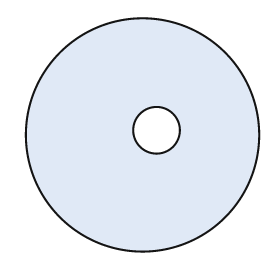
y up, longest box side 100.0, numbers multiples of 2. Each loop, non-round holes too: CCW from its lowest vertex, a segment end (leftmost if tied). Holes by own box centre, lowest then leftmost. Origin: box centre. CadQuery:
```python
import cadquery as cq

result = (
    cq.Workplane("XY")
    .moveTo(0.0, 0.0)
    .circle(50.0)
    .moveTo(6.0, 2.0)
    .circle(10.0)
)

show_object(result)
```